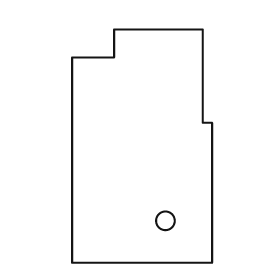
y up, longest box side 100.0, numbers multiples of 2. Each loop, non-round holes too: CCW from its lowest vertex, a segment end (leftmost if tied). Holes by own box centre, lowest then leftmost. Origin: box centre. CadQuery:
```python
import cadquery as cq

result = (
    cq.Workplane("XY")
    .moveTo(-30.0, -50.0)
    .lineTo(30.0, -50.0)
    .lineTo(30.0, 10.0)
    .lineTo(26.0, 10.0)
    .lineTo(26.0, 50.0)
    .lineTo(-12.0, 50.0)
    .lineTo(-12.0, 38.0)
    .lineTo(-30.0, 38.0)
    .close()
    .moveTo(10.0, -32.0)
    .circle(4.0)
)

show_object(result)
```